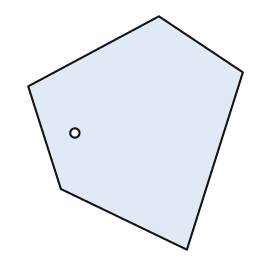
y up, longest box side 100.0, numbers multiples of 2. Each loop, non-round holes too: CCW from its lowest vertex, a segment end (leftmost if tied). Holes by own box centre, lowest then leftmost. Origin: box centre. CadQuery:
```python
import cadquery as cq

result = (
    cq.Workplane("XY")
    .moveTo(22.0, -50.0)
    .lineTo(46.0, 26.0)
    .lineTo(10.0, 50.0)
    .lineTo(-46.0, 20.0)
    .lineTo(-32.0, -24.0)
    .close()
    .moveTo(-26.0, 0.0)
    .circle(2.0)
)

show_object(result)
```